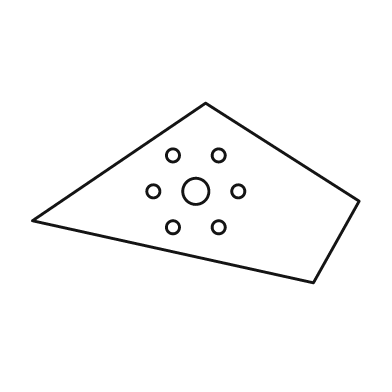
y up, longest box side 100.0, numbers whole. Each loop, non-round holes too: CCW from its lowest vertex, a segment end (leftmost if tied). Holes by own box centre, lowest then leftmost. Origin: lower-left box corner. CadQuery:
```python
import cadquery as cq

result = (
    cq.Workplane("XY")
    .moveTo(86.0, 0.0)
    .lineTo(100.0, 25.0)
    .lineTo(53.0, 55.0)
    .lineTo(0.0, 19.0)
    .close()
    .moveTo(43.0, 17.0)
    .circle(2.0)
    .moveTo(57.0, 17.0)
    .circle(2.0)
    .moveTo(37.0, 28.0)
    .circle(2.0)
    .moveTo(50.0, 28.0)
    .circle(4.0)
    .moveTo(63.0, 28.0)
    .circle(2.0)
    .moveTo(43.0, 39.0)
    .circle(2.0)
    .moveTo(57.0, 39.0)
    .circle(2.0)
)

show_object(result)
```